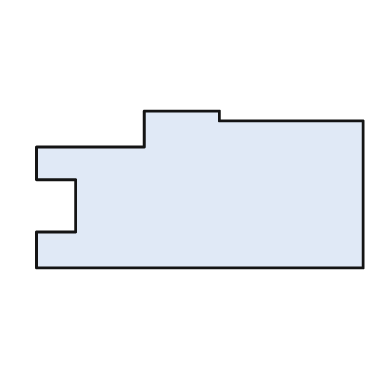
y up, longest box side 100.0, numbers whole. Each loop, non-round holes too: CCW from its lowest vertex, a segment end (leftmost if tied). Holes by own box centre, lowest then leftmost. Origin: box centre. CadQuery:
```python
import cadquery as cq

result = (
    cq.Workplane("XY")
    .moveTo(-50.0, -24.0)
    .lineTo(50.0, -24.0)
    .lineTo(50.0, 21.0)
    .lineTo(6.0, 21.0)
    .lineTo(6.0, 24.0)
    .lineTo(-17.0, 24.0)
    .lineTo(-17.0, 13.0)
    .lineTo(-50.0, 13.0)
    .lineTo(-50.0, 3.0)
    .lineTo(-38.0, 3.0)
    .lineTo(-38.0, -13.0)
    .lineTo(-50.0, -13.0)
    .close()
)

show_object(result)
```